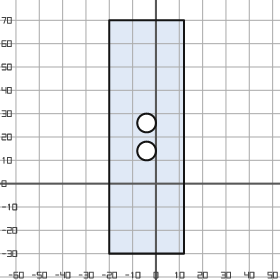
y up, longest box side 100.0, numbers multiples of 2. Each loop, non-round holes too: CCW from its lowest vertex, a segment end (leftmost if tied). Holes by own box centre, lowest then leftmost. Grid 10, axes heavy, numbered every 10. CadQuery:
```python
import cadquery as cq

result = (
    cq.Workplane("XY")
    .moveTo(-20.0, -30.0)
    .lineTo(12.0, -30.0)
    .lineTo(12.0, 70.0)
    .lineTo(-20.0, 70.0)
    .close()
    .moveTo(-4.0, 14.0)
    .circle(4.0)
    .moveTo(-4.0, 26.0)
    .circle(4.0)
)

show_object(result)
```